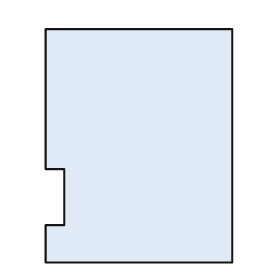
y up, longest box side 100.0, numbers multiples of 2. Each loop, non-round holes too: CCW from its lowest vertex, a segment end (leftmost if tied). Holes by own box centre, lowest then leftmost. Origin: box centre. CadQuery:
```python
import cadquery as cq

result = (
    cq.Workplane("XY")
    .moveTo(-40.0, -50.0)
    .lineTo(40.0, -50.0)
    .lineTo(40.0, 50.0)
    .lineTo(-40.0, 50.0)
    .lineTo(-40.0, -10.0)
    .lineTo(-32.0, -10.0)
    .lineTo(-32.0, -34.0)
    .lineTo(-40.0, -34.0)
    .close()
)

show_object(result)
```